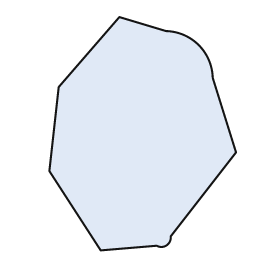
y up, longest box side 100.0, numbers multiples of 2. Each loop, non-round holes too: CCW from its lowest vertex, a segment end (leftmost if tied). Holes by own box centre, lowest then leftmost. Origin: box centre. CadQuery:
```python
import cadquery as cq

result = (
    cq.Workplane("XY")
    .moveTo(-18.0, -50.0)
    .lineTo(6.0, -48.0)
    .threePointArc((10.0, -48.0), (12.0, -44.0))
    .lineTo(40.0, -8.0)
    .lineTo(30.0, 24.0)
    .threePointArc((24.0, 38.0), (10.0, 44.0))
    .lineTo(-10.0, 50.0)
    .lineTo(-36.0, 20.0)
    .lineTo(-40.0, -16.0)
    .close()
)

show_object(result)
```